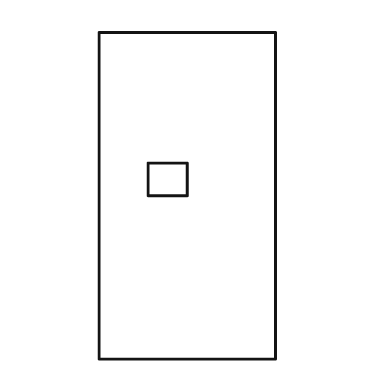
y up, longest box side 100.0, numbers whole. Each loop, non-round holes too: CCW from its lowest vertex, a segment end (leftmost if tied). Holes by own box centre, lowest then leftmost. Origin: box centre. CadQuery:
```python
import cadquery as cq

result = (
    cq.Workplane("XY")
    .moveTo(-27.0, -50.0)
    .lineTo(27.0, -50.0)
    .lineTo(27.0, 50.0)
    .lineTo(-27.0, 50.0)
    .close()
    .moveTo(-12.0, 0.0)
    .lineTo(0.0, 0.0)
    .lineTo(0.0, 10.0)
    .lineTo(-12.0, 10.0)
    .close()
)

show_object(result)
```